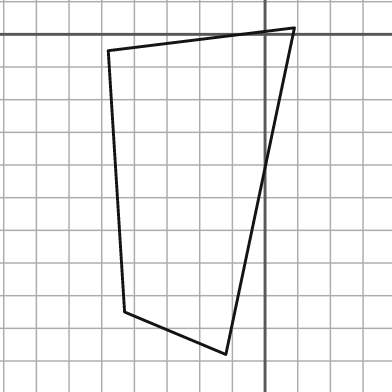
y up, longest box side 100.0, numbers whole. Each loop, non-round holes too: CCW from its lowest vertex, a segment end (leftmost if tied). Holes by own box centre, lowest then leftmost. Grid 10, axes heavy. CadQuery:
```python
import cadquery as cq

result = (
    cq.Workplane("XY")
    .moveTo(-12.0, -98.0)
    .lineTo(9.0, 2.0)
    .lineTo(-48.0, -5.0)
    .lineTo(-43.0, -85.0)
    .close()
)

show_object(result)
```